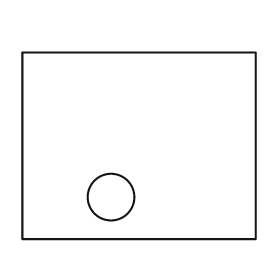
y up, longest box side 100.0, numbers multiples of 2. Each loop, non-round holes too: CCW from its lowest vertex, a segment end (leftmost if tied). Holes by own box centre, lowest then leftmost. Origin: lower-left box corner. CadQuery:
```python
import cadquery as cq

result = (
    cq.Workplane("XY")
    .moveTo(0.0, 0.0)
    .lineTo(100.0, 0.0)
    .lineTo(100.0, 80.0)
    .lineTo(0.0, 80.0)
    .close()
    .moveTo(38.0, 18.0)
    .circle(10.0)
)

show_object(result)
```